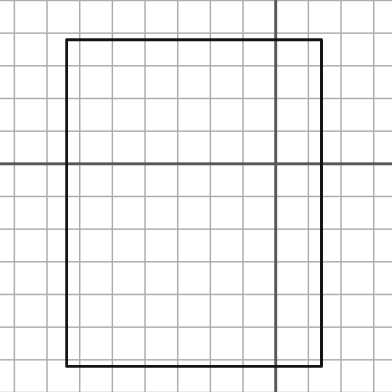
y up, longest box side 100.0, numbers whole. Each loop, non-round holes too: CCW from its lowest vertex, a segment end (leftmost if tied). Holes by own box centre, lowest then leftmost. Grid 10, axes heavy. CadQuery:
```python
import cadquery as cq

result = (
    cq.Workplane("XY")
    .moveTo(-64.0, -62.0)
    .lineTo(14.0, -62.0)
    .lineTo(14.0, 38.0)
    .lineTo(-64.0, 38.0)
    .close()
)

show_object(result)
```